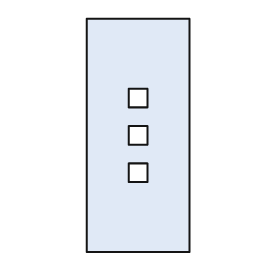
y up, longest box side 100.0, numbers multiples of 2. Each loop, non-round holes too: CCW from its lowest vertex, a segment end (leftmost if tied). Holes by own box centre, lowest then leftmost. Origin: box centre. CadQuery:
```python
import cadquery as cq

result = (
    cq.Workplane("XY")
    .moveTo(-22.0, -50.0)
    .lineTo(22.0, -50.0)
    .lineTo(22.0, 50.0)
    .lineTo(-22.0, 50.0)
    .close()
    .moveTo(-4.0, -20.0)
    .lineTo(4.0, -20.0)
    .lineTo(4.0, -12.0)
    .lineTo(-4.0, -12.0)
    .close()
    .moveTo(-4.0, -4.0)
    .lineTo(4.0, -4.0)
    .lineTo(4.0, 4.0)
    .lineTo(-4.0, 4.0)
    .close()
    .moveTo(-4.0, 12.0)
    .lineTo(4.0, 12.0)
    .lineTo(4.0, 20.0)
    .lineTo(-4.0, 20.0)
    .close()
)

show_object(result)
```